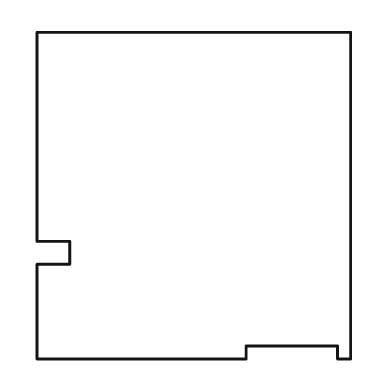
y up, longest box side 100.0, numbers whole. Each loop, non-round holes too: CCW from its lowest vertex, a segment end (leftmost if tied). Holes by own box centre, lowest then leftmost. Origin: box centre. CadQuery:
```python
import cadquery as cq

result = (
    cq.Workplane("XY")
    .moveTo(-48.0, -50.0)
    .lineTo(16.0, -50.0)
    .lineTo(16.0, -46.0)
    .lineTo(44.0, -46.0)
    .lineTo(44.0, -50.0)
    .lineTo(48.0, -50.0)
    .lineTo(48.0, 50.0)
    .lineTo(-48.0, 50.0)
    .lineTo(-48.0, -14.0)
    .lineTo(-38.0, -14.0)
    .lineTo(-38.0, -21.0)
    .lineTo(-48.0, -21.0)
    .close()
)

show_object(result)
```